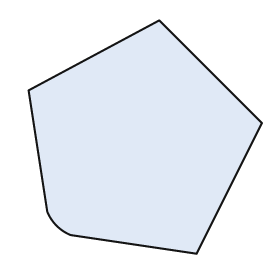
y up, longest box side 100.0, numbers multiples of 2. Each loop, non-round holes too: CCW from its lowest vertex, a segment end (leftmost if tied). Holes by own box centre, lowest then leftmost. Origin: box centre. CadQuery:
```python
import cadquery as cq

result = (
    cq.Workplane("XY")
    .moveTo(22.0, -50.0)
    .lineTo(50.0, 6.0)
    .lineTo(6.0, 50.0)
    .lineTo(-50.0, 20.0)
    .lineTo(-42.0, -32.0)
    .threePointArc((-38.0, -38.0), (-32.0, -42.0))
    .close()
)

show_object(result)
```